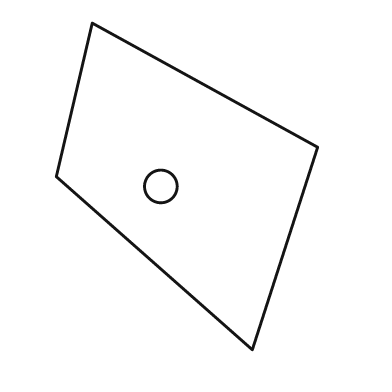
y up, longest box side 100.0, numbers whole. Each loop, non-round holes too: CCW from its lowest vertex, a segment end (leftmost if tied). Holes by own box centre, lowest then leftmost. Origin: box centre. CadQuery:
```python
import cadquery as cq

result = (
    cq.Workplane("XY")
    .moveTo(20.0, -50.0)
    .lineTo(40.0, 12.0)
    .lineTo(-29.0, 50.0)
    .lineTo(-40.0, 3.0)
    .close()
    .moveTo(-8.0, 0.0)
    .circle(5.0)
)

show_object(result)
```